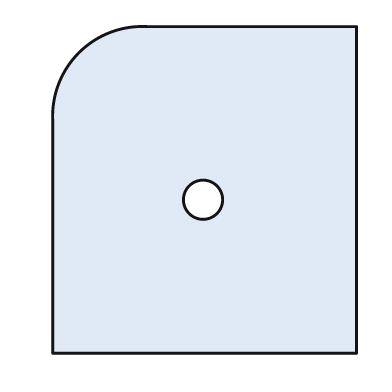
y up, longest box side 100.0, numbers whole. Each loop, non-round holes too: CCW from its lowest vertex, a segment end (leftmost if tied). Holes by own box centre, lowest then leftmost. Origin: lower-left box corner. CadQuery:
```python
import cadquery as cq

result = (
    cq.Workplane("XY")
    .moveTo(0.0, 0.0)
    .lineTo(93.0, 0.0)
    .lineTo(93.0, 100.0)
    .lineTo(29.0, 100.0)
    .threePointArc((8.0, 92.0), (0.0, 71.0))
    .close()
    .moveTo(46.0, 47.0)
    .circle(6.0)
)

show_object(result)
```